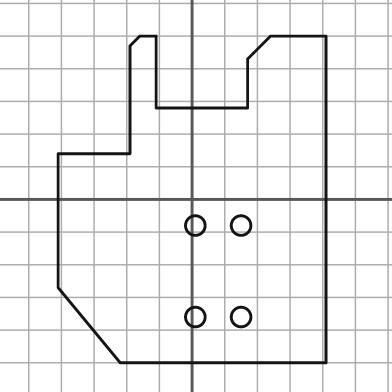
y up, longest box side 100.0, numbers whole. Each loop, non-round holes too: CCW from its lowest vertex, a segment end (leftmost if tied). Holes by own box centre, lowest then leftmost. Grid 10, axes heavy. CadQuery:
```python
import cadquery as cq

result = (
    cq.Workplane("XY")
    .moveTo(-22.0, -50.0)
    .lineTo(41.0, -50.0)
    .lineTo(41.0, 50.0)
    .lineTo(24.0, 50.0)
    .lineTo(17.0, 43.0)
    .lineTo(17.0, 28.0)
    .lineTo(-11.0, 28.0)
    .lineTo(-11.0, 50.0)
    .lineTo(-16.0, 50.0)
    .lineTo(-19.0, 47.0)
    .lineTo(-19.0, 14.0)
    .lineTo(-41.0, 14.0)
    .lineTo(-41.0, -27.0)
    .close()
    .moveTo(1.0, -36.0)
    .circle(3.0)
    .moveTo(15.0, -36.0)
    .circle(3.0)
    .moveTo(1.0, -8.0)
    .circle(3.0)
    .moveTo(15.0, -8.0)
    .circle(3.0)
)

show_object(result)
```